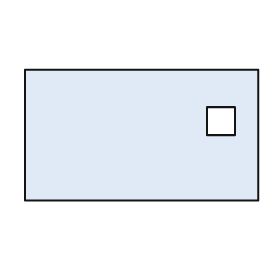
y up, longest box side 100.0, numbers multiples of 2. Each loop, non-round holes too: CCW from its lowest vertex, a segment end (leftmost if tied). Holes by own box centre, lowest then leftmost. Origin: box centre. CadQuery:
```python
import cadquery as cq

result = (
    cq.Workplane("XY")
    .moveTo(-50.0, -28.0)
    .lineTo(50.0, -28.0)
    .lineTo(50.0, 28.0)
    .lineTo(-50.0, 28.0)
    .close()
    .moveTo(28.0, 0.0)
    .lineTo(40.0, 0.0)
    .lineTo(40.0, 12.0)
    .lineTo(28.0, 12.0)
    .close()
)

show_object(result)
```